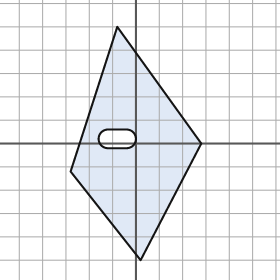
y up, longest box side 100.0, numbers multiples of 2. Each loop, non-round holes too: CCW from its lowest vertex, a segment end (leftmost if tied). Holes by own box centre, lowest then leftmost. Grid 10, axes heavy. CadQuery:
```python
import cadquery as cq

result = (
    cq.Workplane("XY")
    .moveTo(2.0, -50.0)
    .lineTo(28.0, 0.0)
    .lineTo(-8.0, 50.0)
    .lineTo(-28.0, -12.0)
    .close()
    .moveTo(-12.0, -2.0)
    .lineTo(-4.0, -2.0)
    .threePointArc((0.0, 2.0), (-4.0, 6.0))
    .lineTo(-12.0, 6.0)
    .threePointArc((-16.0, 2.0), (-12.0, -2.0))
    .close()
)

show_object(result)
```